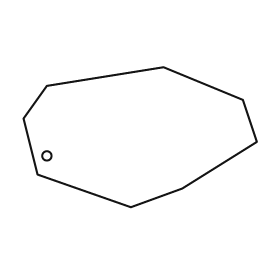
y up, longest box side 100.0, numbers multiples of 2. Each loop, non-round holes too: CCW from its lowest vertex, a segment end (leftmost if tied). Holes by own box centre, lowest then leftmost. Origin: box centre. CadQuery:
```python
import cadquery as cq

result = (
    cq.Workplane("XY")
    .moveTo(-4.0, -30.0)
    .lineTo(18.0, -22.0)
    .lineTo(50.0, -2.0)
    .lineTo(44.0, 16.0)
    .lineTo(10.0, 30.0)
    .lineTo(-40.0, 22.0)
    .lineTo(-50.0, 8.0)
    .lineTo(-44.0, -16.0)
    .close()
    .moveTo(-40.0, -8.0)
    .circle(2.0)
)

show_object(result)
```